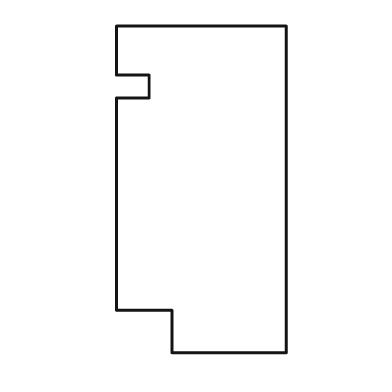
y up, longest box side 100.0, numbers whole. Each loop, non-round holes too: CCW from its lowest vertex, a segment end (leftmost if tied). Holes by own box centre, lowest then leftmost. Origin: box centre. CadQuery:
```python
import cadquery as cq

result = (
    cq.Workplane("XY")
    .moveTo(-9.0, -50.0)
    .lineTo(26.0, -50.0)
    .lineTo(26.0, 50.0)
    .lineTo(-26.0, 50.0)
    .lineTo(-26.0, 35.0)
    .lineTo(-16.0, 35.0)
    .lineTo(-16.0, 28.0)
    .lineTo(-26.0, 28.0)
    .lineTo(-26.0, -37.0)
    .lineTo(-9.0, -37.0)
    .close()
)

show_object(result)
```